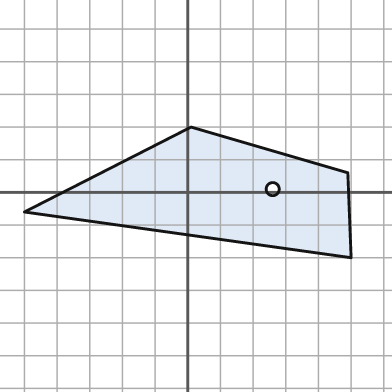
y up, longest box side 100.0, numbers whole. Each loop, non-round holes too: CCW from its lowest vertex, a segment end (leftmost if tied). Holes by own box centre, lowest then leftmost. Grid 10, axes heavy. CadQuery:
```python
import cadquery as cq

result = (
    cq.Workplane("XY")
    .moveTo(50.0, -20.0)
    .lineTo(49.0, 6.0)
    .lineTo(1.0, 20.0)
    .lineTo(-50.0, -6.0)
    .close()
    .moveTo(26.0, 1.0)
    .circle(2.0)
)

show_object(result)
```